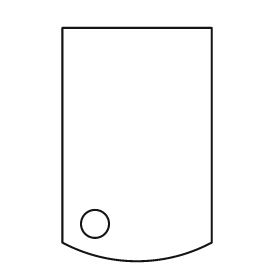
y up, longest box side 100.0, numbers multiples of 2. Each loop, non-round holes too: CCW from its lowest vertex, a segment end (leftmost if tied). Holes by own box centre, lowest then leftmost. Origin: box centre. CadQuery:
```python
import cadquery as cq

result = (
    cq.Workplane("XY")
    .moveTo(-32.0, -42.0)
    .threePointArc((0.0, -50.0), (32.0, -42.0))
    .lineTo(32.0, 50.0)
    .lineTo(-32.0, 50.0)
    .close()
    .moveTo(-18.0, -34.0)
    .circle(6.0)
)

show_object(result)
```